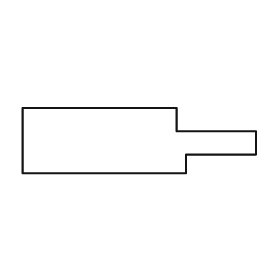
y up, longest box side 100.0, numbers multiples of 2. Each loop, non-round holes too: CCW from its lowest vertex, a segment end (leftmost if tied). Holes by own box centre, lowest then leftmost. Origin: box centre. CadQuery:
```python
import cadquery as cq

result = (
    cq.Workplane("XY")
    .moveTo(-50.0, -14.0)
    .lineTo(20.0, -14.0)
    .lineTo(20.0, -6.0)
    .lineTo(50.0, -6.0)
    .lineTo(50.0, 4.0)
    .lineTo(16.0, 4.0)
    .lineTo(16.0, 14.0)
    .lineTo(-50.0, 14.0)
    .close()
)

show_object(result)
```